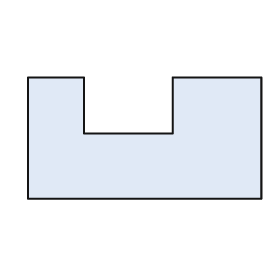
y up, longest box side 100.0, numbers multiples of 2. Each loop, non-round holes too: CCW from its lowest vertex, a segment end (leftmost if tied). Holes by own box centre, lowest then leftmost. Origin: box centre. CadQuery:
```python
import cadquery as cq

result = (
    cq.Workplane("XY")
    .moveTo(-50.0, -26.0)
    .lineTo(50.0, -26.0)
    .lineTo(50.0, 26.0)
    .lineTo(12.0, 26.0)
    .lineTo(12.0, 2.0)
    .lineTo(-26.0, 2.0)
    .lineTo(-26.0, 26.0)
    .lineTo(-50.0, 26.0)
    .close()
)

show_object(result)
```